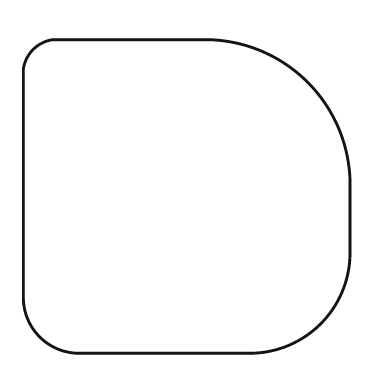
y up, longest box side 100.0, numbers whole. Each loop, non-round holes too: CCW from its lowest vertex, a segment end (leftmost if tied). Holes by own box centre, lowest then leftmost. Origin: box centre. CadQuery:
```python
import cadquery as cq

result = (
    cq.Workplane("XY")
    .moveTo(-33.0, -48.0)
    .lineTo(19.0, -48.0)
    .threePointArc((41.0, -39.0), (50.0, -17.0))
    .lineTo(50.0, 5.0)
    .threePointArc((37.0, 35.0), (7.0, 48.0))
    .lineTo(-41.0, 48.0)
    .threePointArc((-47.0, 45.0), (-50.0, 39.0))
    .lineTo(-50.0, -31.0)
    .threePointArc((-45.0, -43.0), (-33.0, -48.0))
    .close()
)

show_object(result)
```